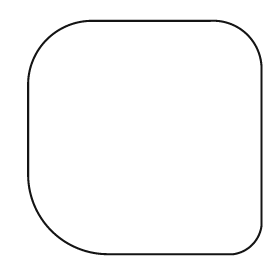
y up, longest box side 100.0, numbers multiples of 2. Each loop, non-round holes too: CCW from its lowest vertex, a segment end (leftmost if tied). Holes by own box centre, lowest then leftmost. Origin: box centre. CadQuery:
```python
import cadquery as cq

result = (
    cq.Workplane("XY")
    .moveTo(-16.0, -50.0)
    .lineTo(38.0, -50.0)
    .threePointArc((46.0, -46.0), (50.0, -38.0))
    .lineTo(50.0, 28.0)
    .threePointArc((44.0, 44.0), (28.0, 50.0))
    .lineTo(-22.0, 50.0)
    .threePointArc((-42.0, 42.0), (-50.0, 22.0))
    .lineTo(-50.0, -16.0)
    .threePointArc((-40.0, -40.0), (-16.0, -50.0))
    .close()
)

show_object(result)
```